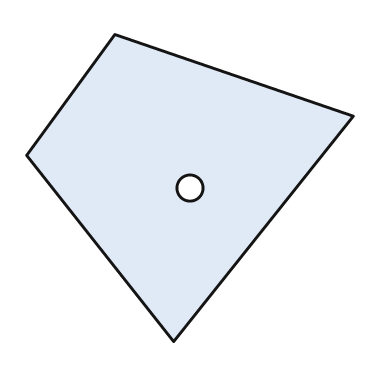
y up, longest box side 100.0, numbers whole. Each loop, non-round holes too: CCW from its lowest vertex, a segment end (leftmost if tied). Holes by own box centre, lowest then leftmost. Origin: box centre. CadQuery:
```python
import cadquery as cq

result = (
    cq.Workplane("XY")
    .moveTo(-5.0, -47.0)
    .lineTo(50.0, 22.0)
    .lineTo(-23.0, 47.0)
    .lineTo(-50.0, 10.0)
    .close()
    .moveTo(0.0, 0.0)
    .circle(4.0)
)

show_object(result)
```